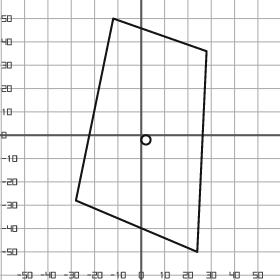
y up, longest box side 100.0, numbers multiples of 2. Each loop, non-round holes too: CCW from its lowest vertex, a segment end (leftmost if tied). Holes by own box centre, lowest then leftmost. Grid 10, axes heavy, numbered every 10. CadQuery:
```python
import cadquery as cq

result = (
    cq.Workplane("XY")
    .moveTo(24.0, -50.0)
    .lineTo(28.0, 36.0)
    .lineTo(-12.0, 50.0)
    .lineTo(-28.0, -28.0)
    .close()
    .moveTo(2.0, -2.0)
    .circle(2.0)
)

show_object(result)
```